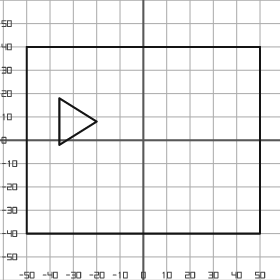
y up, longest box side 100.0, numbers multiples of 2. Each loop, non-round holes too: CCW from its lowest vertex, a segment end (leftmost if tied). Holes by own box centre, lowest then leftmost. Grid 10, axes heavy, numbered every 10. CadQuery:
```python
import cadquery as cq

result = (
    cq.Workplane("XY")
    .moveTo(-50.0, -40.0)
    .lineTo(50.0, -40.0)
    .lineTo(50.0, 40.0)
    .lineTo(-50.0, 40.0)
    .close()
    .moveTo(-36.0, -2.0)
    .lineTo(-20.0, 8.0)
    .lineTo(-36.0, 18.0)
    .close()
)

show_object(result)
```